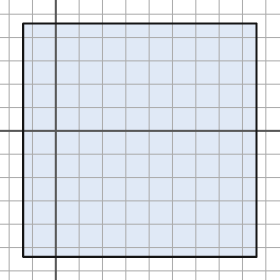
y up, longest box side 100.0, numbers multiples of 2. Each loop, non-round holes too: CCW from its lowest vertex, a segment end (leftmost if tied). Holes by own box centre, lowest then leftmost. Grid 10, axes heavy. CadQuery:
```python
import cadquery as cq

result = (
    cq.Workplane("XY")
    .moveTo(-14.0, -54.0)
    .lineTo(86.0, -54.0)
    .lineTo(86.0, 46.0)
    .lineTo(-14.0, 46.0)
    .close()
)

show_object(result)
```